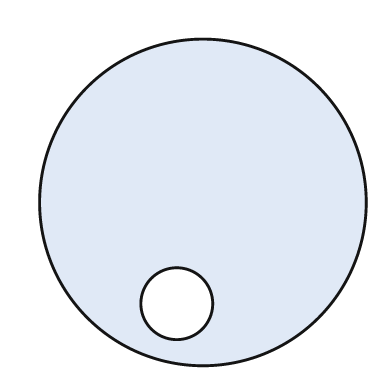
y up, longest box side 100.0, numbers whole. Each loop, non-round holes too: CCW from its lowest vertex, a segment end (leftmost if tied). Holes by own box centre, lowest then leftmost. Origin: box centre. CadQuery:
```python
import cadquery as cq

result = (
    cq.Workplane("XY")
    .moveTo(0.0, 0.0)
    .circle(50.0)
    .moveTo(-8.0, -31.0)
    .circle(11.0)
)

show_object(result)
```